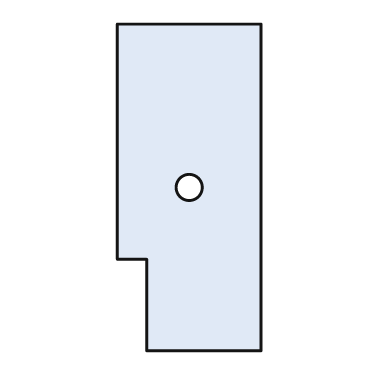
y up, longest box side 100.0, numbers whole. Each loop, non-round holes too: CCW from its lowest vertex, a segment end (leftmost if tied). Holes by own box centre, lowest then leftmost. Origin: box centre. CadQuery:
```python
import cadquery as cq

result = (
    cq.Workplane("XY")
    .moveTo(-13.0, -50.0)
    .lineTo(22.0, -50.0)
    .lineTo(22.0, 50.0)
    .lineTo(-22.0, 50.0)
    .lineTo(-22.0, -22.0)
    .lineTo(-13.0, -22.0)
    .close()
    .moveTo(0.0, 0.0)
    .circle(4.0)
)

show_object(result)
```